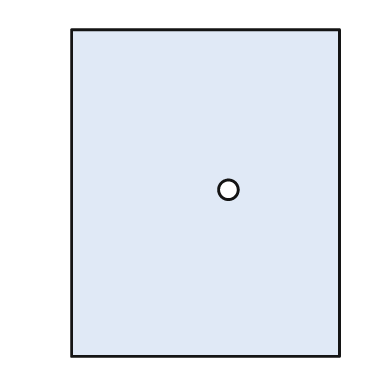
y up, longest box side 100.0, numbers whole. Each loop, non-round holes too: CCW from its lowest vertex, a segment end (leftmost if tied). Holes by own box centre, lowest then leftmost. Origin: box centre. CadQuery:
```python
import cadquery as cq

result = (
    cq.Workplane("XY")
    .moveTo(-41.0, -50.0)
    .lineTo(41.0, -50.0)
    .lineTo(41.0, 50.0)
    .lineTo(-41.0, 50.0)
    .close()
    .moveTo(7.0, 1.0)
    .circle(3.0)
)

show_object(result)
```